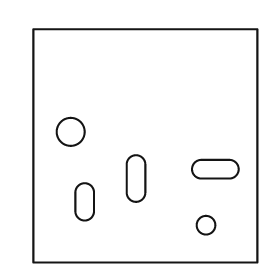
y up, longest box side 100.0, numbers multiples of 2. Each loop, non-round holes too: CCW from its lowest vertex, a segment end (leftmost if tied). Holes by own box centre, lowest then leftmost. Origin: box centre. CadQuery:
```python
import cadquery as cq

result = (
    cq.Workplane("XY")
    .moveTo(-48.0, -50.0)
    .lineTo(48.0, -50.0)
    .lineTo(48.0, 50.0)
    .lineTo(-48.0, 50.0)
    .close()
    .moveTo(26.0, -34.0)
    .circle(4.0)
    .moveTo(-30.0, -28.0)
    .threePointArc((-26.0, -32.0), (-22.0, -28.0))
    .lineTo(-22.0, -20.0)
    .threePointArc((-26.0, -16.0), (-30.0, -20.0))
    .close()
    .moveTo(-8.0, -20.0)
    .threePointArc((-4.0, -24.0), (0.0, -20.0))
    .lineTo(0.0, -8.0)
    .threePointArc((-4.0, -4.0), (-8.0, -8.0))
    .close()
    .moveTo(24.0, -14.0)
    .lineTo(36.0, -14.0)
    .threePointArc((40.0, -10.0), (36.0, -6.0))
    .lineTo(24.0, -6.0)
    .threePointArc((20.0, -10.0), (24.0, -14.0))
    .close()
    .moveTo(-32.0, 6.0)
    .circle(6.0)
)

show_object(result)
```